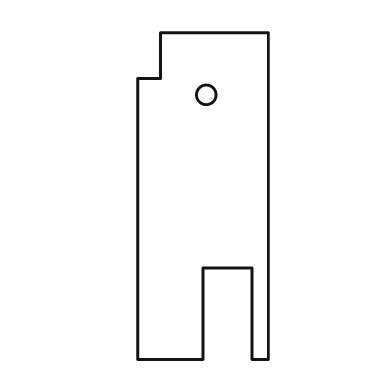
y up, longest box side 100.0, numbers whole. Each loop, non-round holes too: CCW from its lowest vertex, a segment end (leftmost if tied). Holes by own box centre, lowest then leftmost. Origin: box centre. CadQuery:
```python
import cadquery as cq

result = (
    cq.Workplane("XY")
    .moveTo(-20.0, -50.0)
    .lineTo(0.0, -50.0)
    .lineTo(0.0, -22.0)
    .lineTo(15.0, -22.0)
    .lineTo(15.0, -50.0)
    .lineTo(20.0, -50.0)
    .lineTo(20.0, 50.0)
    .lineTo(-13.0, 50.0)
    .lineTo(-13.0, 36.0)
    .lineTo(-20.0, 36.0)
    .close()
    .moveTo(1.0, 31.0)
    .circle(3.0)
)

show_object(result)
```